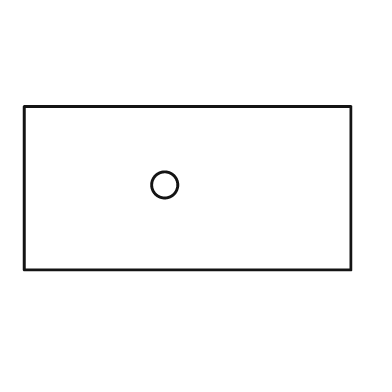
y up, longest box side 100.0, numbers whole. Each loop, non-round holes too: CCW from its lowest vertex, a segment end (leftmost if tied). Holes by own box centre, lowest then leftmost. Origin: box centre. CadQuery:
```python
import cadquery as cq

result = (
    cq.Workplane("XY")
    .moveTo(-50.0, -25.0)
    .lineTo(50.0, -25.0)
    .lineTo(50.0, 25.0)
    .lineTo(-50.0, 25.0)
    .close()
    .moveTo(-7.0, 1.0)
    .circle(4.0)
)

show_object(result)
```